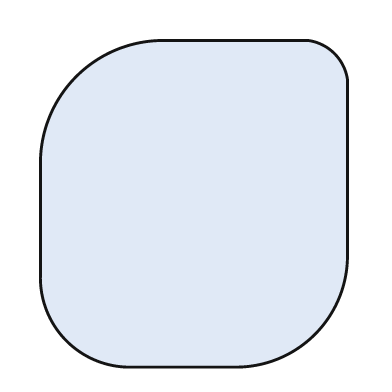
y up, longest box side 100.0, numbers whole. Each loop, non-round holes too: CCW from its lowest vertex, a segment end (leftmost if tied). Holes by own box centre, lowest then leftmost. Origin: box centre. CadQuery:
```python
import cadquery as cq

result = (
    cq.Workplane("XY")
    .moveTo(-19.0, -50.0)
    .lineTo(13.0, -50.0)
    .threePointArc((37.0, -40.0), (47.0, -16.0))
    .lineTo(47.0, 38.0)
    .threePointArc((43.0, 46.0), (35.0, 50.0))
    .lineTo(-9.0, 50.0)
    .threePointArc((-36.0, 39.0), (-47.0, 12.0))
    .lineTo(-47.0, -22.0)
    .threePointArc((-39.0, -42.0), (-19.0, -50.0))
    .close()
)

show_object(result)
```